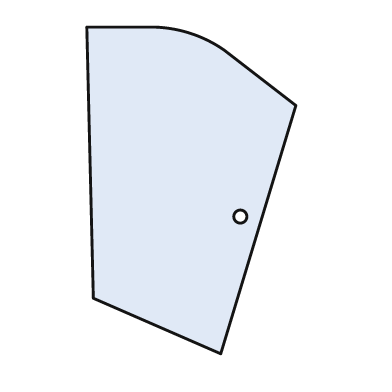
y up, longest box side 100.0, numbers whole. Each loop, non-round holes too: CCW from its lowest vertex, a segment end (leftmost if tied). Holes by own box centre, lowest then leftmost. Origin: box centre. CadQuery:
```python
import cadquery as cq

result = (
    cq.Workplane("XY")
    .moveTo(9.0, -50.0)
    .lineTo(32.0, 26.0)
    .lineTo(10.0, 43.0)
    .threePointArc((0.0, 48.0), (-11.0, 50.0))
    .lineTo(-32.0, 50.0)
    .lineTo(-30.0, -33.0)
    .close()
    .moveTo(15.0, -8.0)
    .circle(2.0)
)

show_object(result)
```